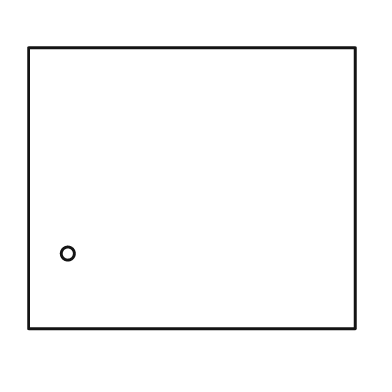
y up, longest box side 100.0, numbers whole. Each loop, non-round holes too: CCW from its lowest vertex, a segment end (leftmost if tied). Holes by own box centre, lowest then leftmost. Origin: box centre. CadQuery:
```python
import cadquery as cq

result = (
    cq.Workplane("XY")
    .moveTo(-50.0, -43.0)
    .lineTo(50.0, -43.0)
    .lineTo(50.0, 43.0)
    .lineTo(-50.0, 43.0)
    .close()
    .moveTo(-38.0, -20.0)
    .circle(2.0)
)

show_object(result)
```